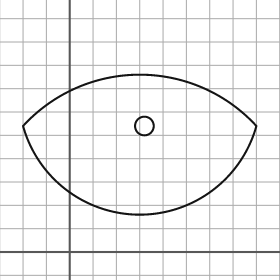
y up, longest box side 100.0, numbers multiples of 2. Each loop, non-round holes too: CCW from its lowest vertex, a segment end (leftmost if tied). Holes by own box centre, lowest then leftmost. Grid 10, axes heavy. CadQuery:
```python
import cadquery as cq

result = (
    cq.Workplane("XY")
    .moveTo(-20.0, 54.0)
    .threePointArc((30.0, 16.0), (80.0, 54.0))
    .threePointArc((30.0, 76.0), (-20.0, 54.0))
    .close()
    .moveTo(32.0, 54.0)
    .circle(4.0)
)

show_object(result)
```